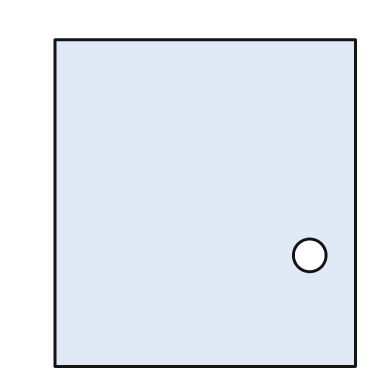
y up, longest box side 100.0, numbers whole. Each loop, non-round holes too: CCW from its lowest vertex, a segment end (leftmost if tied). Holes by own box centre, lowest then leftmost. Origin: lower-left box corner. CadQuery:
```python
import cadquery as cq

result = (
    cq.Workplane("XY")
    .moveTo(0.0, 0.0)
    .lineTo(92.0, 0.0)
    .lineTo(92.0, 100.0)
    .lineTo(0.0, 100.0)
    .close()
    .moveTo(78.0, 34.0)
    .circle(5.0)
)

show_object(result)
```